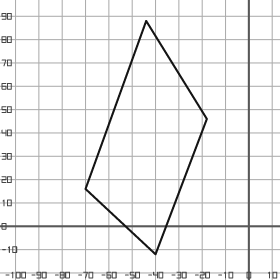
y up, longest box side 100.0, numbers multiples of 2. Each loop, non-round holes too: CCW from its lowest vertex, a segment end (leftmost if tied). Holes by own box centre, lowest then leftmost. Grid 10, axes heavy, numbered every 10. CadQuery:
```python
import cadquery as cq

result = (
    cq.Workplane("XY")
    .moveTo(-40.0, -12.0)
    .lineTo(-18.0, 46.0)
    .lineTo(-44.0, 88.0)
    .lineTo(-70.0, 16.0)
    .close()
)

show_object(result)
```